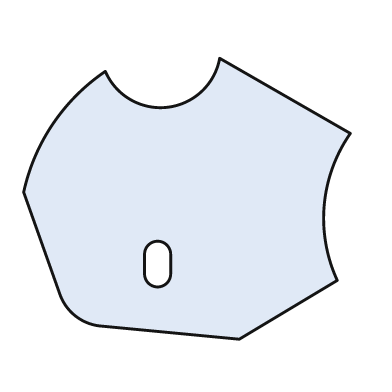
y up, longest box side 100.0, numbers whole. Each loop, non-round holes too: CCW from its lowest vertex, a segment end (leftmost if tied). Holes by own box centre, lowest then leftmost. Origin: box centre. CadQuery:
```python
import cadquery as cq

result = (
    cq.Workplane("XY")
    .moveTo(16.0, -43.0)
    .lineTo(46.0, -25.0)
    .threePointArc((42.0, -2.0), (50.0, 20.0))
    .lineTo(10.0, 43.0)
    .threePointArc((-6.0, 28.0), (-25.0, 39.0))
    .threePointArc((-41.0, 23.0), (-50.0, 2.0))
    .lineTo(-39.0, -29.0)
    .threePointArc((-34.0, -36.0), (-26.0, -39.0))
    .close()
    .moveTo(-13.0, -23.0)
    .threePointArc((-9.0, -27.0), (-5.0, -23.0))
    .lineTo(-5.0, -17.0)
    .threePointArc((-9.0, -13.0), (-13.0, -17.0))
    .close()
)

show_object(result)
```